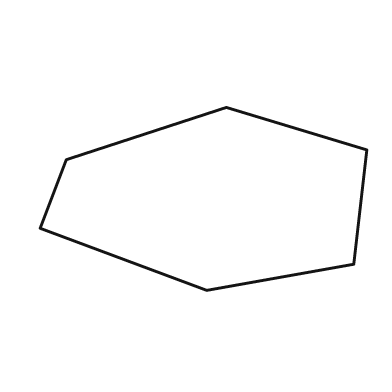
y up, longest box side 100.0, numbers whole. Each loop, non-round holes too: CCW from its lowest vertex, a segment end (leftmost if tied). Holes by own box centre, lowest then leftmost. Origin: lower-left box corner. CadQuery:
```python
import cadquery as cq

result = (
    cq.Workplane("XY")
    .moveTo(51.0, 0.0)
    .lineTo(96.0, 8.0)
    .lineTo(100.0, 43.0)
    .lineTo(57.0, 56.0)
    .lineTo(8.0, 40.0)
    .lineTo(0.0, 19.0)
    .close()
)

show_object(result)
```